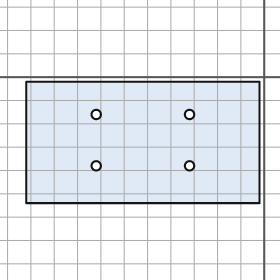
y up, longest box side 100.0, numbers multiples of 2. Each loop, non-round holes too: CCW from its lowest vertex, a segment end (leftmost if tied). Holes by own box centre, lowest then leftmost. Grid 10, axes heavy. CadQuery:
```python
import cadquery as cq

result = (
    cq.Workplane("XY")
    .moveTo(-102.0, -54.0)
    .lineTo(-2.0, -54.0)
    .lineTo(-2.0, -2.0)
    .lineTo(-102.0, -2.0)
    .close()
    .moveTo(-72.0, -38.0)
    .circle(2.0)
    .moveTo(-32.0, -38.0)
    .circle(2.0)
    .moveTo(-72.0, -16.0)
    .circle(2.0)
    .moveTo(-32.0, -16.0)
    .circle(2.0)
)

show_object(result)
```